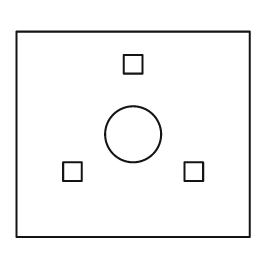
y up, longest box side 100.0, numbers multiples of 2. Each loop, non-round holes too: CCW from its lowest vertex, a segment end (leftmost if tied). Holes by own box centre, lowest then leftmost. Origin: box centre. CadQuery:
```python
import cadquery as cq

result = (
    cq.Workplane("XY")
    .moveTo(-50.0, -44.0)
    .lineTo(50.0, -44.0)
    .lineTo(50.0, 44.0)
    .lineTo(-50.0, 44.0)
    .close()
    .moveTo(-30.0, -20.0)
    .lineTo(-22.0, -20.0)
    .lineTo(-22.0, -12.0)
    .lineTo(-30.0, -12.0)
    .close()
    .moveTo(22.0, -20.0)
    .lineTo(30.0, -20.0)
    .lineTo(30.0, -12.0)
    .lineTo(22.0, -12.0)
    .close()
    .moveTo(0.0, 0.0)
    .circle(12.0)
    .moveTo(-4.0, 26.0)
    .lineTo(4.0, 26.0)
    .lineTo(4.0, 34.0)
    .lineTo(-4.0, 34.0)
    .close()
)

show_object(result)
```